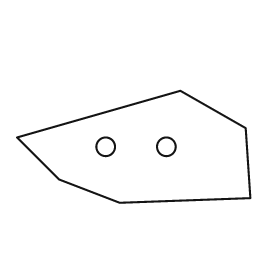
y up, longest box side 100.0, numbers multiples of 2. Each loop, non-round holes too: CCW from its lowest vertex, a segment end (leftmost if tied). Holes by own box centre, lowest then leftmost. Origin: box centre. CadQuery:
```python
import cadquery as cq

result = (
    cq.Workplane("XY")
    .moveTo(-6.0, -24.0)
    .lineTo(50.0, -22.0)
    .lineTo(48.0, 8.0)
    .lineTo(20.0, 24.0)
    .lineTo(-50.0, 4.0)
    .lineTo(-32.0, -14.0)
    .close()
    .moveTo(-12.0, 0.0)
    .circle(4.0)
    .moveTo(14.0, 0.0)
    .circle(4.0)
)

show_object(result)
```